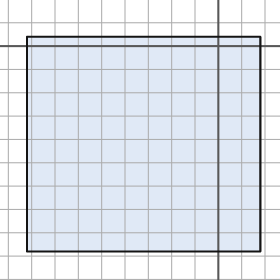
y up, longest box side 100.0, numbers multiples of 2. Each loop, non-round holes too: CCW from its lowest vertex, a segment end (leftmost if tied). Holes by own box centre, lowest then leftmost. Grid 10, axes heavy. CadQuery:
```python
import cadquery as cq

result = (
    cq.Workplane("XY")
    .moveTo(-82.0, -88.0)
    .lineTo(18.0, -88.0)
    .lineTo(18.0, 4.0)
    .lineTo(-82.0, 4.0)
    .close()
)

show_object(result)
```